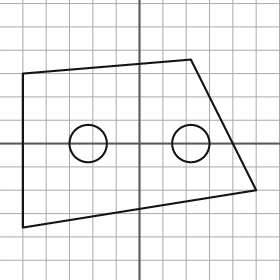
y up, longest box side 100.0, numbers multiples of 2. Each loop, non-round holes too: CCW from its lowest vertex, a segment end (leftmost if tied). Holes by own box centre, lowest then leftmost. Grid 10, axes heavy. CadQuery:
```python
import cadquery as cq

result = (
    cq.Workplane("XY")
    .moveTo(-50.0, -36.0)
    .lineTo(50.0, -20.0)
    .lineTo(22.0, 36.0)
    .lineTo(-50.0, 30.0)
    .close()
    .moveTo(-22.0, 0.0)
    .circle(8.0)
    .moveTo(22.0, 0.0)
    .circle(8.0)
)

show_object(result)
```